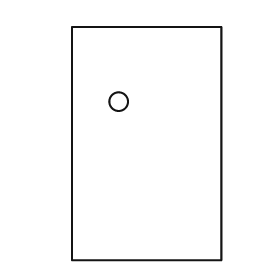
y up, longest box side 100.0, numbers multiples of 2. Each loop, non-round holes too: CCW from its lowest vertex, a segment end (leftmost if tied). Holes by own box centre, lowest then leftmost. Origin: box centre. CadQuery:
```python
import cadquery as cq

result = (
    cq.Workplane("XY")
    .moveTo(-32.0, -50.0)
    .lineTo(32.0, -50.0)
    .lineTo(32.0, 50.0)
    .lineTo(-32.0, 50.0)
    .close()
    .moveTo(-12.0, 18.0)
    .circle(4.0)
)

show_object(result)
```